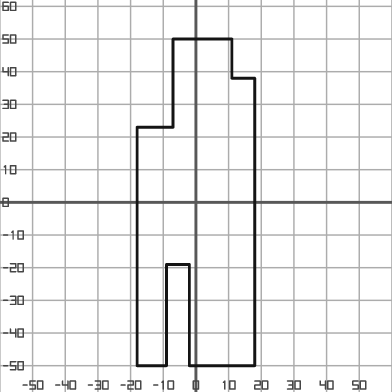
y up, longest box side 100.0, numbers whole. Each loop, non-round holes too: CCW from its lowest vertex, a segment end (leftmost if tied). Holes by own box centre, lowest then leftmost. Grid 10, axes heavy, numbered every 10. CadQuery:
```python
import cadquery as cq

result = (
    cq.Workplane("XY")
    .moveTo(-18.0, -50.0)
    .lineTo(-9.0, -50.0)
    .lineTo(-9.0, -19.0)
    .lineTo(-2.0, -19.0)
    .lineTo(-2.0, -50.0)
    .lineTo(18.0, -50.0)
    .lineTo(18.0, 38.0)
    .lineTo(11.0, 38.0)
    .lineTo(11.0, 50.0)
    .lineTo(-7.0, 50.0)
    .lineTo(-7.0, 23.0)
    .lineTo(-18.0, 23.0)
    .close()
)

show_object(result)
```